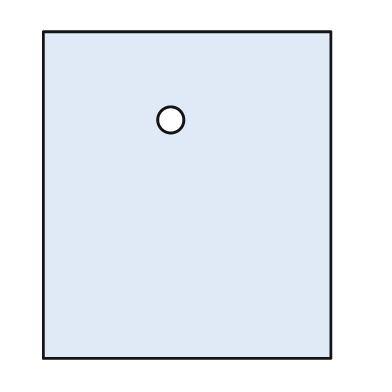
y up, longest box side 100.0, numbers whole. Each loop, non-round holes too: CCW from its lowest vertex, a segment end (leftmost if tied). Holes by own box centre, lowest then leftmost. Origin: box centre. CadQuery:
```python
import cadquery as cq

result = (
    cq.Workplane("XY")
    .moveTo(-44.0, -50.0)
    .lineTo(44.0, -50.0)
    .lineTo(44.0, 50.0)
    .lineTo(-44.0, 50.0)
    .close()
    .moveTo(-5.0, 23.0)
    .circle(4.0)
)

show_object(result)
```